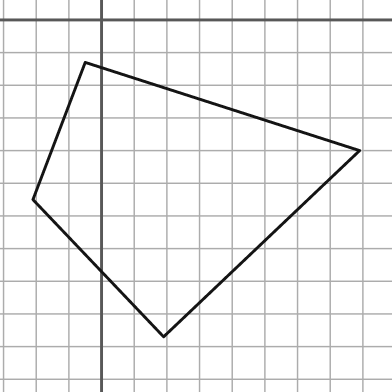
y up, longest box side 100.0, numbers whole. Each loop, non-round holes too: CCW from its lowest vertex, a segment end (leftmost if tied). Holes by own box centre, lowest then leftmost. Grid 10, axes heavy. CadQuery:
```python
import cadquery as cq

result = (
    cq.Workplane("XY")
    .moveTo(19.0, -97.0)
    .lineTo(79.0, -40.0)
    .lineTo(-5.0, -13.0)
    .lineTo(-21.0, -55.0)
    .close()
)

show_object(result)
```